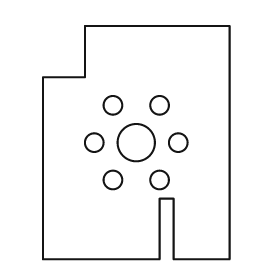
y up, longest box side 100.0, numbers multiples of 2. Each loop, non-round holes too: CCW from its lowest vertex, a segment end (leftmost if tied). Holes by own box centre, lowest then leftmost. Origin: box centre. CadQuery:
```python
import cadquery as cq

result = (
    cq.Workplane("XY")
    .moveTo(-40.0, -50.0)
    .lineTo(10.0, -50.0)
    .lineTo(10.0, -24.0)
    .lineTo(16.0, -24.0)
    .lineTo(16.0, -50.0)
    .lineTo(40.0, -50.0)
    .lineTo(40.0, 50.0)
    .lineTo(-22.0, 50.0)
    .lineTo(-22.0, 28.0)
    .lineTo(-40.0, 28.0)
    .close()
    .moveTo(-10.0, -16.0)
    .circle(4.0)
    .moveTo(10.0, -16.0)
    .circle(4.0)
    .moveTo(-18.0, 0.0)
    .circle(4.0)
    .moveTo(0.0, 0.0)
    .circle(8.0)
    .moveTo(18.0, 0.0)
    .circle(4.0)
    .moveTo(-10.0, 16.0)
    .circle(4.0)
    .moveTo(10.0, 16.0)
    .circle(4.0)
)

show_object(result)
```